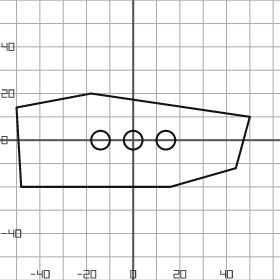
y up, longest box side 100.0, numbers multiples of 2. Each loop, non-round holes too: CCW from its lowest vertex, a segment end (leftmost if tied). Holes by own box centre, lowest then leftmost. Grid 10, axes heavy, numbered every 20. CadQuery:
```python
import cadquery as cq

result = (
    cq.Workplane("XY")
    .moveTo(-48.0, -20.0)
    .lineTo(16.0, -20.0)
    .lineTo(44.0, -12.0)
    .lineTo(50.0, 10.0)
    .lineTo(-18.0, 20.0)
    .lineTo(-50.0, 14.0)
    .close()
    .moveTo(-14.0, 0.0)
    .circle(4.0)
    .moveTo(0.0, 0.0)
    .circle(4.0)
    .moveTo(14.0, 0.0)
    .circle(4.0)
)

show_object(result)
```